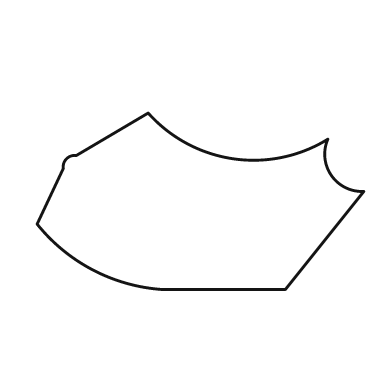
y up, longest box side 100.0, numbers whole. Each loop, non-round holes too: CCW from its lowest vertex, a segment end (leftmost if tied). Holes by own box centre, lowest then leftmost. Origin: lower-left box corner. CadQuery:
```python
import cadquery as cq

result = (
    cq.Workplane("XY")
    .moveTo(38.0, 0.0)
    .lineTo(76.0, 0.0)
    .lineTo(100.0, 30.0)
    .threePointArc((90.0, 35.0), (89.0, 46.0))
    .threePointArc((60.0, 40.0), (34.0, 54.0))
    .lineTo(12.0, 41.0)
    .threePointArc((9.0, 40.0), (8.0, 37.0))
    .lineTo(0.0, 20.0)
    .threePointArc((17.0, 6.0), (38.0, 0.0))
    .close()
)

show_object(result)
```